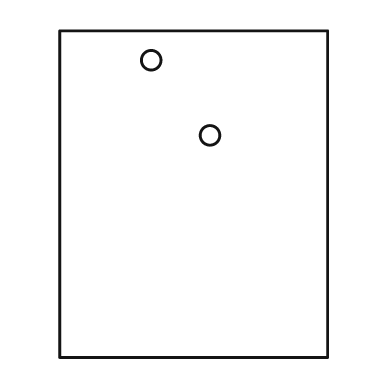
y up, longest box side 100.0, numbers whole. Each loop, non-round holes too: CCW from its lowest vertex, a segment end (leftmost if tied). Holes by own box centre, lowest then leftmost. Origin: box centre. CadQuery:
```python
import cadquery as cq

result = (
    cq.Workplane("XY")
    .moveTo(-41.0, -50.0)
    .lineTo(41.0, -50.0)
    .lineTo(41.0, 50.0)
    .lineTo(-41.0, 50.0)
    .close()
    .moveTo(5.0, 18.0)
    .circle(3.0)
    .moveTo(-13.0, 41.0)
    .circle(3.0)
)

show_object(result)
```